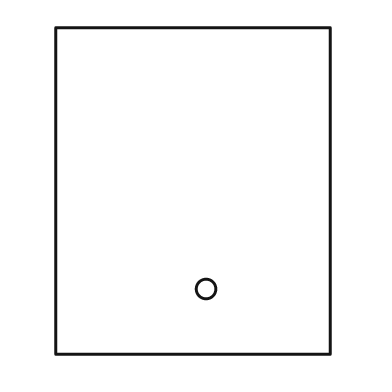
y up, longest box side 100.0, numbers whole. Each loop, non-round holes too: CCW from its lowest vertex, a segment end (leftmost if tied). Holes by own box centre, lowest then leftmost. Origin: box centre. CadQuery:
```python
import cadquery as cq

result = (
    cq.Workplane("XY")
    .moveTo(-42.0, -50.0)
    .lineTo(42.0, -50.0)
    .lineTo(42.0, 50.0)
    .lineTo(-42.0, 50.0)
    .close()
    .moveTo(4.0, -30.0)
    .circle(3.0)
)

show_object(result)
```